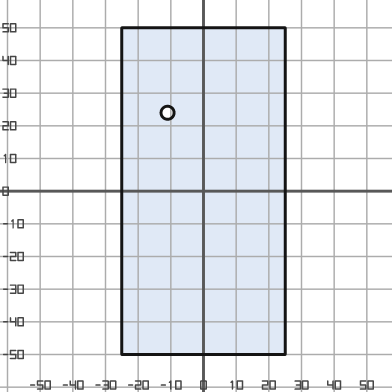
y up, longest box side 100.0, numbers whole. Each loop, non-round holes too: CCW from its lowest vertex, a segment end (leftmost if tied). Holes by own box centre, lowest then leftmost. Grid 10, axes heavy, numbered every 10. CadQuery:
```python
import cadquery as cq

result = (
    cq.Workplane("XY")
    .moveTo(-25.0, -50.0)
    .lineTo(25.0, -50.0)
    .lineTo(25.0, 50.0)
    .lineTo(-25.0, 50.0)
    .close()
    .moveTo(-11.0, 24.0)
    .circle(2.0)
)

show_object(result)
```